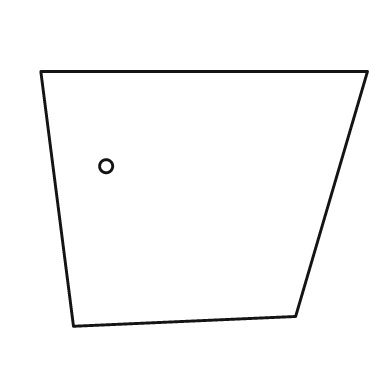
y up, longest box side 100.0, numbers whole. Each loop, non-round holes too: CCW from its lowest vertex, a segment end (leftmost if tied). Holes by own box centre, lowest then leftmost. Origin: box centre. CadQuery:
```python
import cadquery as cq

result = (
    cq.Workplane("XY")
    .moveTo(-40.0, -39.0)
    .lineTo(28.0, -36.0)
    .lineTo(50.0, 39.0)
    .lineTo(-50.0, 39.0)
    .close()
    .moveTo(-30.0, 10.0)
    .circle(2.0)
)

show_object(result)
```